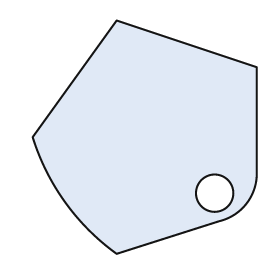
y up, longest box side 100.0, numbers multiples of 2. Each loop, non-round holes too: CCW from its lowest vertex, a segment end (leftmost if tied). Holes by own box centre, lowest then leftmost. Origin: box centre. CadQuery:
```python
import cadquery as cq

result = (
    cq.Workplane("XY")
    .moveTo(-12.0, -50.0)
    .lineTo(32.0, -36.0)
    .threePointArc((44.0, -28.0), (48.0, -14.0))
    .lineTo(48.0, 30.0)
    .lineTo(-12.0, 50.0)
    .lineTo(-48.0, 0.0)
    .threePointArc((-34.0, -28.0), (-12.0, -50.0))
    .close()
    .moveTo(30.0, -24.0)
    .circle(8.0)
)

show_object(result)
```